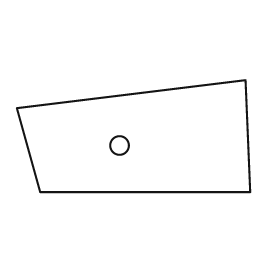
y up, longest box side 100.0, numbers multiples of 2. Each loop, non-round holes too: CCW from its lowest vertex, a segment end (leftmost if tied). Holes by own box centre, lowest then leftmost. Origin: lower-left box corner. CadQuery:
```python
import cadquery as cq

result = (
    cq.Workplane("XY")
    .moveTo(10.0, 0.0)
    .lineTo(100.0, 0.0)
    .lineTo(98.0, 48.0)
    .lineTo(0.0, 36.0)
    .close()
    .moveTo(44.0, 20.0)
    .circle(4.0)
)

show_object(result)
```